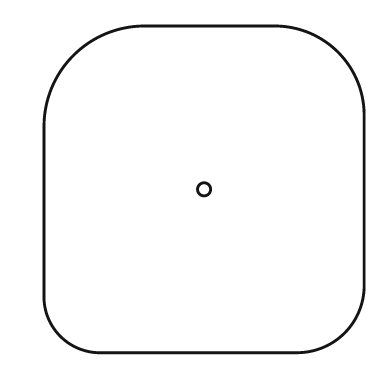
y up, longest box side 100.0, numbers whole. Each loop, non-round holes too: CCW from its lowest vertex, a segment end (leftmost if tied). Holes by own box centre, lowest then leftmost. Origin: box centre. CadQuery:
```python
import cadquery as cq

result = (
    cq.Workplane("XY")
    .moveTo(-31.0, -50.0)
    .lineTo(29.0, -50.0)
    .threePointArc((43.0, -44.0), (49.0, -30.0))
    .lineTo(49.0, 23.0)
    .threePointArc((41.0, 42.0), (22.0, 50.0))
    .lineTo(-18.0, 50.0)
    .threePointArc((-40.0, 41.0), (-49.0, 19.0))
    .lineTo(-49.0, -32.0)
    .threePointArc((-44.0, -45.0), (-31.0, -50.0))
    .close()
    .moveTo(0.0, 0.0)
    .circle(2.0)
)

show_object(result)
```